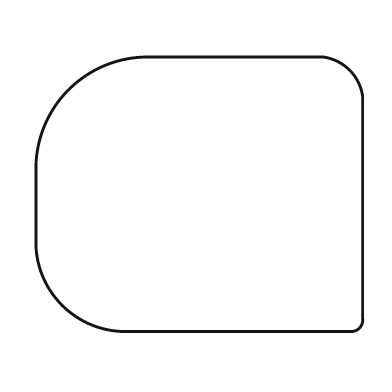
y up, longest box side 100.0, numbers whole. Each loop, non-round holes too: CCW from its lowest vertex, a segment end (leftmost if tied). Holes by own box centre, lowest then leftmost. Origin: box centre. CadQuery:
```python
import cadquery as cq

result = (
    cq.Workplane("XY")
    .moveTo(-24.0, -42.0)
    .lineTo(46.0, -42.0)
    .threePointArc((49.0, -41.0), (50.0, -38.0))
    .lineTo(50.0, 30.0)
    .threePointArc((46.0, 38.0), (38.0, 42.0))
    .lineTo(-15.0, 42.0)
    .threePointArc((-40.0, 32.0), (-50.0, 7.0))
    .lineTo(-50.0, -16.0)
    .threePointArc((-42.0, -34.0), (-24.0, -42.0))
    .close()
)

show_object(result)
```